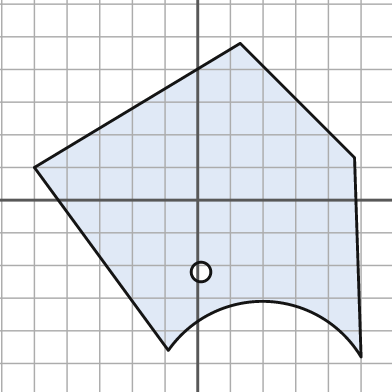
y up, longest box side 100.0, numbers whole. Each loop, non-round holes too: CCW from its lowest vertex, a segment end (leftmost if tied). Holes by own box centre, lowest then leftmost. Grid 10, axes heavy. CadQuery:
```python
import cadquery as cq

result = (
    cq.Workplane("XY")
    .moveTo(50.0, -48.0)
    .lineTo(48.0, 13.0)
    .lineTo(13.0, 48.0)
    .lineTo(-50.0, 10.0)
    .lineTo(-9.0, -46.0)
    .threePointArc((21.0, -31.0), (50.0, -48.0))
    .close()
    .moveTo(1.0, -22.0)
    .circle(3.0)
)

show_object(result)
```